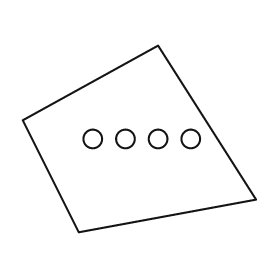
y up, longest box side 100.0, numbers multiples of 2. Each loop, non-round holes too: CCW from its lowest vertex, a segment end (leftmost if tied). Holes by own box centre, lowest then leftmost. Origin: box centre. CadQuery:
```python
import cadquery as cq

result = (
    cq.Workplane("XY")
    .moveTo(-26.0, -40.0)
    .lineTo(50.0, -26.0)
    .lineTo(8.0, 40.0)
    .lineTo(-50.0, 8.0)
    .close()
    .moveTo(-20.0, 0.0)
    .circle(4.0)
    .moveTo(-6.0, 0.0)
    .circle(4.0)
    .moveTo(8.0, 0.0)
    .circle(4.0)
    .moveTo(22.0, 0.0)
    .circle(4.0)
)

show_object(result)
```